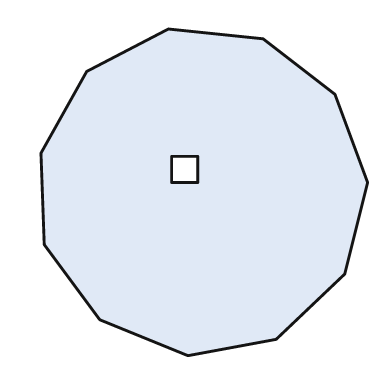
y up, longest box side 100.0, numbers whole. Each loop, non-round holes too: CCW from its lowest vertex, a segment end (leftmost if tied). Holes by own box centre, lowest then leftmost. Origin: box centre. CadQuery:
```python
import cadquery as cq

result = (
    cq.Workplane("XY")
    .moveTo(-5.0, -50.0)
    .lineTo(22.0, -45.0)
    .lineTo(43.0, -25.0)
    .lineTo(50.0, 3.0)
    .lineTo(40.0, 30.0)
    .lineTo(18.0, 47.0)
    .lineTo(-11.0, 50.0)
    .lineTo(-36.0, 37.0)
    .lineTo(-50.0, 12.0)
    .lineTo(-49.0, -16.0)
    .lineTo(-32.0, -39.0)
    .close()
    .moveTo(-10.0, 3.0)
    .lineTo(-2.0, 3.0)
    .lineTo(-2.0, 11.0)
    .lineTo(-10.0, 11.0)
    .close()
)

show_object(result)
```